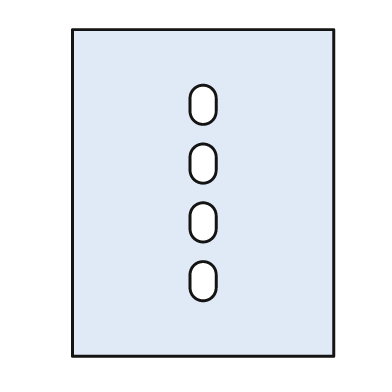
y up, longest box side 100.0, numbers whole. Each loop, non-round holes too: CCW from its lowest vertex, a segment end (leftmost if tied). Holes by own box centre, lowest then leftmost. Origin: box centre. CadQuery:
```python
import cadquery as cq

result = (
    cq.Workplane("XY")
    .moveTo(-40.0, -50.0)
    .lineTo(40.0, -50.0)
    .lineTo(40.0, 50.0)
    .lineTo(-40.0, 50.0)
    .close()
    .moveTo(-4.0, -29.0)
    .threePointArc((0.0, -33.0), (4.0, -29.0))
    .lineTo(4.0, -25.0)
    .threePointArc((0.0, -21.0), (-4.0, -25.0))
    .close()
    .moveTo(-4.0, -11.0)
    .threePointArc((0.0, -15.0), (4.0, -11.0))
    .lineTo(4.0, -7.0)
    .threePointArc((0.0, -3.0), (-4.0, -7.0))
    .close()
    .moveTo(-4.0, 7.0)
    .threePointArc((0.0, 3.0), (4.0, 7.0))
    .lineTo(4.0, 11.0)
    .threePointArc((0.0, 15.0), (-4.0, 11.0))
    .close()
    .moveTo(-4.0, 25.0)
    .threePointArc((0.0, 21.0), (4.0, 25.0))
    .lineTo(4.0, 29.0)
    .threePointArc((0.0, 33.0), (-4.0, 29.0))
    .close()
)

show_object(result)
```